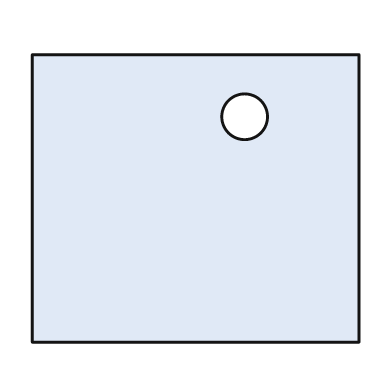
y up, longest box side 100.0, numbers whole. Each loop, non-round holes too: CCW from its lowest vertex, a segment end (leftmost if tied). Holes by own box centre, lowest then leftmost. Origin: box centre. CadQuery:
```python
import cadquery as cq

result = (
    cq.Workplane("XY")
    .moveTo(-50.0, -44.0)
    .lineTo(50.0, -44.0)
    .lineTo(50.0, 44.0)
    .lineTo(-50.0, 44.0)
    .close()
    .moveTo(15.0, 25.0)
    .circle(7.0)
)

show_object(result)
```